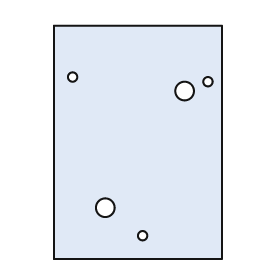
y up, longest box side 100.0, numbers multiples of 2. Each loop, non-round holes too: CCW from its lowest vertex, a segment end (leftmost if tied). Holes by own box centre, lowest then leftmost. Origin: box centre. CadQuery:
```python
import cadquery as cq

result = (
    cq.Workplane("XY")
    .moveTo(-36.0, -50.0)
    .lineTo(36.0, -50.0)
    .lineTo(36.0, 50.0)
    .lineTo(-36.0, 50.0)
    .close()
    .moveTo(2.0, -40.0)
    .circle(2.0)
    .moveTo(-14.0, -28.0)
    .circle(4.0)
    .moveTo(20.0, 22.0)
    .circle(4.0)
    .moveTo(30.0, 26.0)
    .circle(2.0)
    .moveTo(-28.0, 28.0)
    .circle(2.0)
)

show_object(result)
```